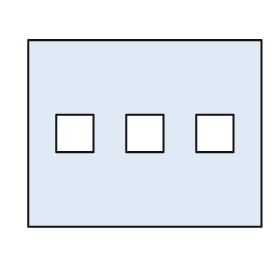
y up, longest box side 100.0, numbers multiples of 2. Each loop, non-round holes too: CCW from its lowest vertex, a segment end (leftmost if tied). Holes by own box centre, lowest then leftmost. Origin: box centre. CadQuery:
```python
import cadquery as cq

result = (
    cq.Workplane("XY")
    .moveTo(-50.0, -40.0)
    .lineTo(50.0, -40.0)
    .lineTo(50.0, 40.0)
    .lineTo(-50.0, 40.0)
    .close()
    .moveTo(-38.0, -8.0)
    .lineTo(-22.0, -8.0)
    .lineTo(-22.0, 8.0)
    .lineTo(-38.0, 8.0)
    .close()
    .moveTo(-8.0, -8.0)
    .lineTo(8.0, -8.0)
    .lineTo(8.0, 8.0)
    .lineTo(-8.0, 8.0)
    .close()
    .moveTo(22.0, -8.0)
    .lineTo(38.0, -8.0)
    .lineTo(38.0, 8.0)
    .lineTo(22.0, 8.0)
    .close()
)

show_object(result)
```